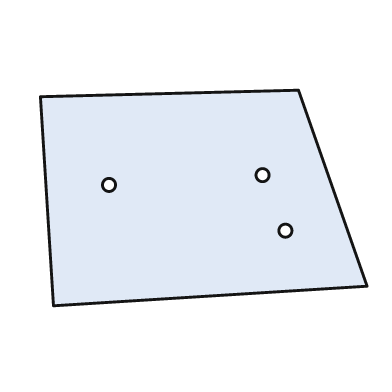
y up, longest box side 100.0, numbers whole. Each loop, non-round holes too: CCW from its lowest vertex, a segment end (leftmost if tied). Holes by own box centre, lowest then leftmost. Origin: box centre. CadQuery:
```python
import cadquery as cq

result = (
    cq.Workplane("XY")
    .moveTo(-46.0, -33.0)
    .lineTo(50.0, -27.0)
    .lineTo(29.0, 33.0)
    .lineTo(-50.0, 31.0)
    .close()
    .moveTo(25.0, -10.0)
    .circle(2.0)
    .moveTo(-29.0, 4.0)
    .circle(2.0)
    .moveTo(18.0, 7.0)
    .circle(2.0)
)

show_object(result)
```